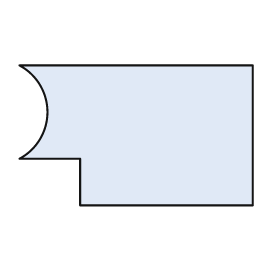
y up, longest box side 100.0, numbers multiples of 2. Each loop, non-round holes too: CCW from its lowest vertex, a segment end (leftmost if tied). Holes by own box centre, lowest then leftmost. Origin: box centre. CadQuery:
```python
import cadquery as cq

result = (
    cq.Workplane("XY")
    .moveTo(-24.0, -30.0)
    .lineTo(50.0, -30.0)
    .lineTo(50.0, 30.0)
    .lineTo(-50.0, 30.0)
    .threePointArc((-38.0, 10.0), (-50.0, -10.0))
    .lineTo(-24.0, -10.0)
    .close()
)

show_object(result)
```